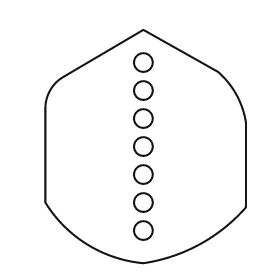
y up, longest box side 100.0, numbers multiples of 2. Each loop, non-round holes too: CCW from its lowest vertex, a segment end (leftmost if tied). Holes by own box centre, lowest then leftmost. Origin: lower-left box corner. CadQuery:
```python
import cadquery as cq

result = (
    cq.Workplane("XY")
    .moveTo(42.0, 0.0)
    .threePointArc((66.0, 8.0), (86.0, 24.0))
    .lineTo(86.0, 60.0)
    .threePointArc((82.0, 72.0), (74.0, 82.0))
    .lineTo(42.0, 100.0)
    .lineTo(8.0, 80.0)
    .threePointArc((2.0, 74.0), (0.0, 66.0))
    .lineTo(0.0, 26.0)
    .threePointArc((18.0, 8.0), (42.0, 0.0))
    .close()
    .moveTo(42.0, 14.0)
    .circle(4.0)
    .moveTo(42.0, 26.0)
    .circle(4.0)
    .moveTo(42.0, 38.0)
    .circle(4.0)
    .moveTo(42.0, 50.0)
    .circle(4.0)
    .moveTo(42.0, 62.0)
    .circle(4.0)
    .moveTo(42.0, 74.0)
    .circle(4.0)
    .moveTo(42.0, 86.0)
    .circle(4.0)
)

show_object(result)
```